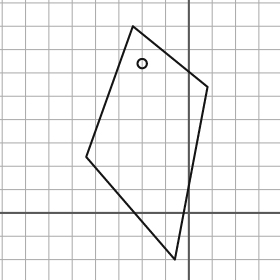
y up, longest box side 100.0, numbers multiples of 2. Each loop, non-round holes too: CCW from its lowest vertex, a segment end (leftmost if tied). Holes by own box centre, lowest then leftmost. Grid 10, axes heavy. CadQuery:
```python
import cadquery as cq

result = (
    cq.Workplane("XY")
    .moveTo(-6.0, -20.0)
    .lineTo(8.0, 54.0)
    .lineTo(-24.0, 80.0)
    .lineTo(-44.0, 24.0)
    .close()
    .moveTo(-20.0, 64.0)
    .circle(2.0)
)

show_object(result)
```